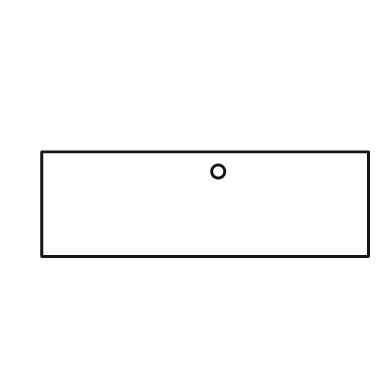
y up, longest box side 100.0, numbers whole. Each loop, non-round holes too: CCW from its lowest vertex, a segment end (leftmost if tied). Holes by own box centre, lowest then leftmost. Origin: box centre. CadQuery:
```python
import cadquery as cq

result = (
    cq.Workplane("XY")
    .moveTo(-50.0, -16.0)
    .lineTo(50.0, -16.0)
    .lineTo(50.0, 16.0)
    .lineTo(-50.0, 16.0)
    .close()
    .moveTo(4.0, 10.0)
    .circle(2.0)
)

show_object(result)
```